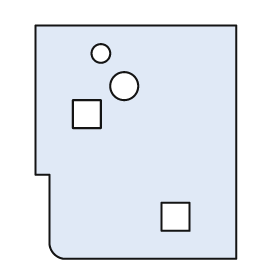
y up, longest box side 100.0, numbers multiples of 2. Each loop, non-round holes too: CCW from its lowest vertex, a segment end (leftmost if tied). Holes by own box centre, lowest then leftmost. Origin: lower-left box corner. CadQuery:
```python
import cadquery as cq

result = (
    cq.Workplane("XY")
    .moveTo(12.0, 0.0)
    .lineTo(86.0, 0.0)
    .lineTo(86.0, 100.0)
    .lineTo(0.0, 100.0)
    .lineTo(0.0, 36.0)
    .lineTo(6.0, 36.0)
    .lineTo(6.0, 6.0)
    .threePointArc((8.0, 2.0), (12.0, 0.0))
    .close()
    .moveTo(54.0, 12.0)
    .lineTo(66.0, 12.0)
    .lineTo(66.0, 24.0)
    .lineTo(54.0, 24.0)
    .close()
    .moveTo(16.0, 56.0)
    .lineTo(28.0, 56.0)
    .lineTo(28.0, 68.0)
    .lineTo(16.0, 68.0)
    .close()
    .moveTo(38.0, 74.0)
    .circle(6.0)
    .moveTo(28.0, 88.0)
    .circle(4.0)
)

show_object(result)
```